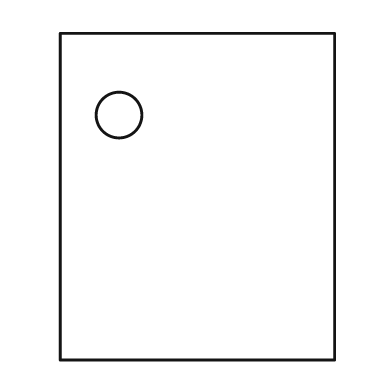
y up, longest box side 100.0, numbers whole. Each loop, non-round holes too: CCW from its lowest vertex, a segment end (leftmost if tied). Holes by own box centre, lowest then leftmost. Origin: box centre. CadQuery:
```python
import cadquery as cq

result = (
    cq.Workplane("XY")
    .moveTo(-42.0, -50.0)
    .lineTo(42.0, -50.0)
    .lineTo(42.0, 50.0)
    .lineTo(-42.0, 50.0)
    .close()
    .moveTo(-24.0, 25.0)
    .circle(7.0)
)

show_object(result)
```